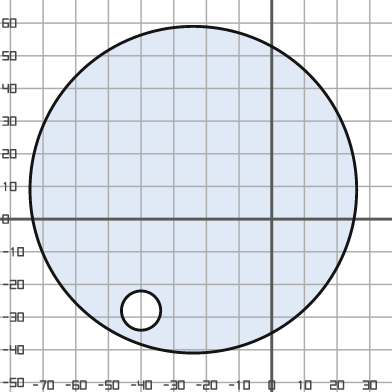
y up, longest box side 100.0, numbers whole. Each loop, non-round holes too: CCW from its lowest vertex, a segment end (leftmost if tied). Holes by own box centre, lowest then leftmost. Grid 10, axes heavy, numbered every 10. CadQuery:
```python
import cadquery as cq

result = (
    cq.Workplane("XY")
    .moveTo(-24.0, 9.0)
    .circle(50.0)
    .moveTo(-40.0, -28.0)
    .circle(6.0)
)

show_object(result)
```